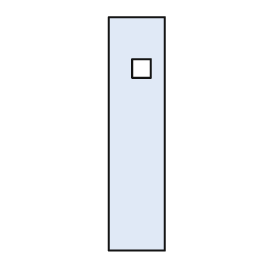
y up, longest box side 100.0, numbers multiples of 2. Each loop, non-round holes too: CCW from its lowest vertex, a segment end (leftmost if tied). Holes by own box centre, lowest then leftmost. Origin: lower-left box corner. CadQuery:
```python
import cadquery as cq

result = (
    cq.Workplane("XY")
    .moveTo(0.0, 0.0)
    .lineTo(24.0, 0.0)
    .lineTo(24.0, 100.0)
    .lineTo(0.0, 100.0)
    .close()
    .moveTo(10.0, 74.0)
    .lineTo(18.0, 74.0)
    .lineTo(18.0, 82.0)
    .lineTo(10.0, 82.0)
    .close()
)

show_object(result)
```